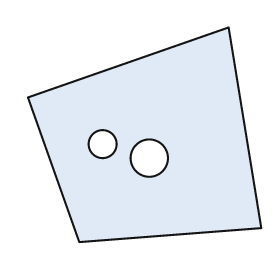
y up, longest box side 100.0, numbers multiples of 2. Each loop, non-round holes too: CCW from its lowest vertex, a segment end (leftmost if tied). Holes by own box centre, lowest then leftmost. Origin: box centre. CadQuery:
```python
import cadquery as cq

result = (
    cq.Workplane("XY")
    .moveTo(-28.0, -46.0)
    .lineTo(50.0, -40.0)
    .lineTo(36.0, 46.0)
    .lineTo(-50.0, 16.0)
    .close()
    .moveTo(2.0, -10.0)
    .circle(8.0)
    .moveTo(-18.0, -4.0)
    .circle(6.0)
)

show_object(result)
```